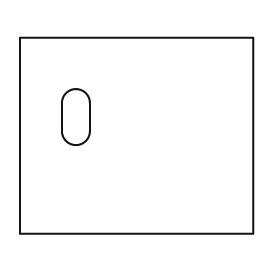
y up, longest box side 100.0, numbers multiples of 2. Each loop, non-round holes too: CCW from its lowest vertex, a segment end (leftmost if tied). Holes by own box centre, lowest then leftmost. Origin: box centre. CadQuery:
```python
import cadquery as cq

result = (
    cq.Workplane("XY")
    .moveTo(-50.0, -42.0)
    .lineTo(50.0, -42.0)
    .lineTo(50.0, 42.0)
    .lineTo(-50.0, 42.0)
    .close()
    .moveTo(-32.0, 2.0)
    .threePointArc((-26.0, -4.0), (-20.0, 2.0))
    .lineTo(-20.0, 14.0)
    .threePointArc((-26.0, 20.0), (-32.0, 14.0))
    .close()
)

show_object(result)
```